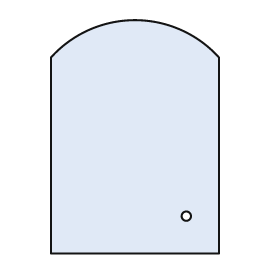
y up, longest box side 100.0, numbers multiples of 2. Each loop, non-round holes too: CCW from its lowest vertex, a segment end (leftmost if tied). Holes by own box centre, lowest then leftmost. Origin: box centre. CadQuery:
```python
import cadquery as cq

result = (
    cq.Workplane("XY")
    .moveTo(-36.0, -50.0)
    .lineTo(36.0, -50.0)
    .lineTo(36.0, 34.0)
    .threePointArc((0.0, 50.0), (-36.0, 34.0))
    .close()
    .moveTo(22.0, -34.0)
    .circle(2.0)
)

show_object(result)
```